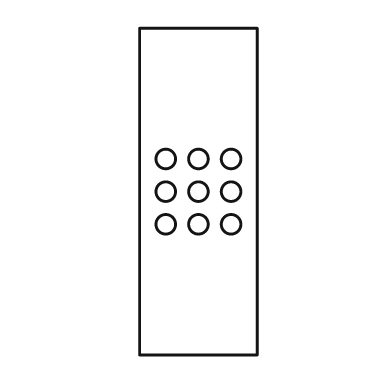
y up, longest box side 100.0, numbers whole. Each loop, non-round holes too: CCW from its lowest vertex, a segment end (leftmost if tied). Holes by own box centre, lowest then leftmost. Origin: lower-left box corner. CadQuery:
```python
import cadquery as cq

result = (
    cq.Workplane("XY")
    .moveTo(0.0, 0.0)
    .lineTo(36.0, 0.0)
    .lineTo(36.0, 100.0)
    .lineTo(0.0, 100.0)
    .close()
    .moveTo(8.0, 40.0)
    .circle(3.0)
    .moveTo(18.0, 40.0)
    .circle(3.0)
    .moveTo(28.0, 40.0)
    .circle(3.0)
    .moveTo(8.0, 50.0)
    .circle(3.0)
    .moveTo(18.0, 50.0)
    .circle(3.0)
    .moveTo(28.0, 50.0)
    .circle(3.0)
    .moveTo(8.0, 60.0)
    .circle(3.0)
    .moveTo(18.0, 60.0)
    .circle(3.0)
    .moveTo(28.0, 60.0)
    .circle(3.0)
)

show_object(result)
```